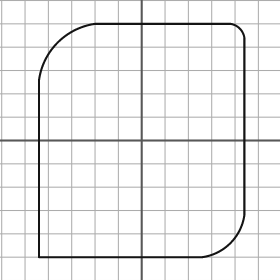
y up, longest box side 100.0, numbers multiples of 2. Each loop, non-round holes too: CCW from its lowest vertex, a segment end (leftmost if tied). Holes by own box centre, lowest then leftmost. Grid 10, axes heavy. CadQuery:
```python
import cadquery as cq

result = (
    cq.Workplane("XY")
    .moveTo(-44.0, -50.0)
    .lineTo(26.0, -50.0)
    .threePointArc((38.0, -44.0), (44.0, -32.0))
    .lineTo(44.0, 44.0)
    .threePointArc((42.0, 48.0), (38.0, 50.0))
    .lineTo(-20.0, 50.0)
    .threePointArc((-36.0, 42.0), (-44.0, 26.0))
    .close()
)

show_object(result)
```